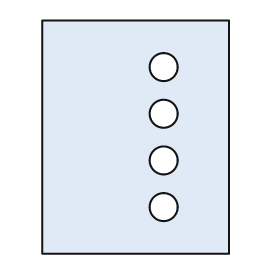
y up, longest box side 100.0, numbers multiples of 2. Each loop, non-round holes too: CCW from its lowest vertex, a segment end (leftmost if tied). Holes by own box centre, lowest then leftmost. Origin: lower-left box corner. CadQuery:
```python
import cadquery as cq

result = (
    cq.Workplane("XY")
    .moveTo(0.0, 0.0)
    .lineTo(80.0, 0.0)
    .lineTo(80.0, 100.0)
    .lineTo(0.0, 100.0)
    .close()
    .moveTo(52.0, 20.0)
    .circle(6.0)
    .moveTo(52.0, 40.0)
    .circle(6.0)
    .moveTo(52.0, 60.0)
    .circle(6.0)
    .moveTo(52.0, 80.0)
    .circle(6.0)
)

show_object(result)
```